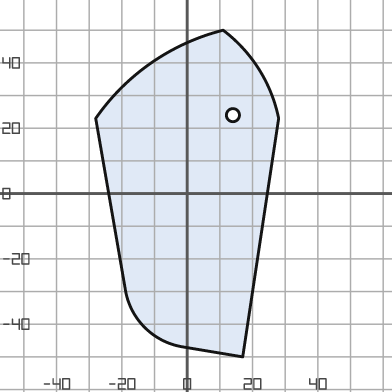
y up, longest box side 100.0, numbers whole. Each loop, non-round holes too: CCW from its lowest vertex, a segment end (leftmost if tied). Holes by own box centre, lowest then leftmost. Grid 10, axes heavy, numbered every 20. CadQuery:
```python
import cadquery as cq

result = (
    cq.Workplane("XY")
    .moveTo(17.0, -50.0)
    .lineTo(28.0, 23.0)
    .threePointArc((22.0, 38.0), (11.0, 50.0))
    .threePointArc((-11.0, 40.0), (-28.0, 23.0))
    .lineTo(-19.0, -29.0)
    .threePointArc((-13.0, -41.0), (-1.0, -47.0))
    .close()
    .moveTo(14.0, 24.0)
    .circle(2.0)
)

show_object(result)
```